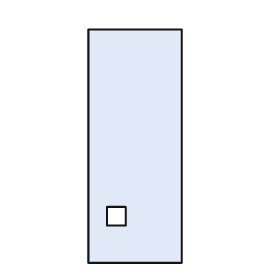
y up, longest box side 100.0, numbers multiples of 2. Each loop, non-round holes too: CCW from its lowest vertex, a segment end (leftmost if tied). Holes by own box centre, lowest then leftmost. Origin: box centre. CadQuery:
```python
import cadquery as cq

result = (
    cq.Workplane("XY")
    .moveTo(-20.0, -50.0)
    .lineTo(20.0, -50.0)
    .lineTo(20.0, 50.0)
    .lineTo(-20.0, 50.0)
    .close()
    .moveTo(-12.0, -34.0)
    .lineTo(-4.0, -34.0)
    .lineTo(-4.0, -26.0)
    .lineTo(-12.0, -26.0)
    .close()
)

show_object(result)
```